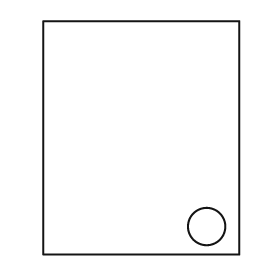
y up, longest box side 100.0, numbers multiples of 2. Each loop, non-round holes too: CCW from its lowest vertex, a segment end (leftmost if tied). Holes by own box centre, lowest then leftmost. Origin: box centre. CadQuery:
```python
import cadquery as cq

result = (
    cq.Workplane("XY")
    .moveTo(-42.0, -50.0)
    .lineTo(42.0, -50.0)
    .lineTo(42.0, 50.0)
    .lineTo(-42.0, 50.0)
    .close()
    .moveTo(28.0, -38.0)
    .circle(8.0)
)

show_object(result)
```